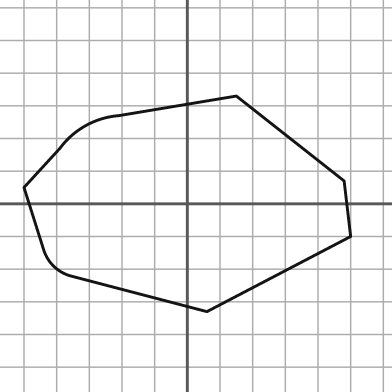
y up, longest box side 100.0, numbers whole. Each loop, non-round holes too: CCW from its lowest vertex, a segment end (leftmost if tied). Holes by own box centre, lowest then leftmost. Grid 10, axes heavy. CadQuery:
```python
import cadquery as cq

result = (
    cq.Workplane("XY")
    .moveTo(6.0, -33.0)
    .lineTo(50.0, -10.0)
    .lineTo(48.0, 7.0)
    .lineTo(15.0, 33.0)
    .lineTo(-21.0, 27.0)
    .threePointArc((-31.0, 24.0), (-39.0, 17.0))
    .lineTo(-50.0, 5.0)
    .lineTo(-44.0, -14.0)
    .threePointArc((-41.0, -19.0), (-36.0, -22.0))
    .close()
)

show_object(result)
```